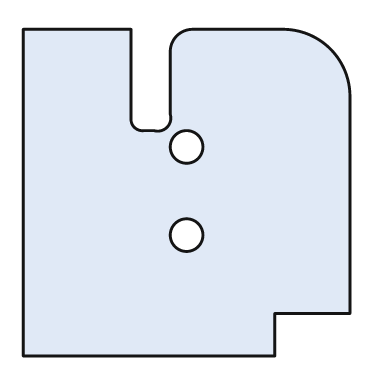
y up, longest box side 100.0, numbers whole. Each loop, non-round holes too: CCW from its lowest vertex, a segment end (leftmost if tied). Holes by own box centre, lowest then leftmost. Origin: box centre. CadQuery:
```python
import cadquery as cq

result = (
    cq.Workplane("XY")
    .moveTo(-50.0, -50.0)
    .lineTo(27.0, -50.0)
    .lineTo(27.0, -37.0)
    .lineTo(50.0, -37.0)
    .lineTo(50.0, 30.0)
    .threePointArc((44.0, 44.0), (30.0, 50.0))
    .lineTo(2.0, 50.0)
    .threePointArc((-3.0, 48.0), (-5.0, 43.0))
    .lineTo(-5.0, 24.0)
    .threePointArc((-6.0, 20.0), (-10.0, 19.0))
    .lineTo(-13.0, 19.0)
    .threePointArc((-16.0, 20.0), (-17.0, 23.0))
    .lineTo(-17.0, 50.0)
    .lineTo(-50.0, 50.0)
    .close()
    .moveTo(0.0, -13.0)
    .circle(5.0)
    .moveTo(0.0, 14.0)
    .circle(5.0)
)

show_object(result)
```